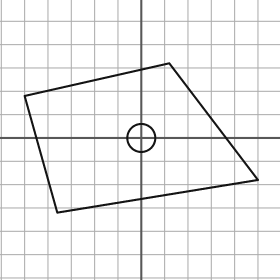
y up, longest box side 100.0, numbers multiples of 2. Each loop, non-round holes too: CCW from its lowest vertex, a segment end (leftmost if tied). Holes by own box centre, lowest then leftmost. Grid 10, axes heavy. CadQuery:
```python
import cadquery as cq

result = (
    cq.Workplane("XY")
    .moveTo(-36.0, -32.0)
    .lineTo(50.0, -18.0)
    .lineTo(12.0, 32.0)
    .lineTo(-50.0, 18.0)
    .close()
    .moveTo(0.0, 0.0)
    .circle(6.0)
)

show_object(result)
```